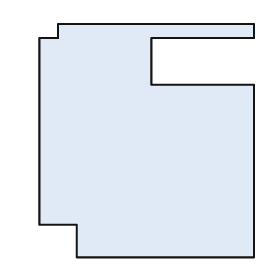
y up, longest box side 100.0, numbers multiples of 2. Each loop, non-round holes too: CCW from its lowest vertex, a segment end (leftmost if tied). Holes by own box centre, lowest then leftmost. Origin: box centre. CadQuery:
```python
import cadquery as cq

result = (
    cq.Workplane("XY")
    .moveTo(-30.0, -50.0)
    .lineTo(46.0, -50.0)
    .lineTo(46.0, 24.0)
    .lineTo(2.0, 24.0)
    .lineTo(2.0, 44.0)
    .lineTo(46.0, 44.0)
    .lineTo(46.0, 50.0)
    .lineTo(-38.0, 50.0)
    .lineTo(-38.0, 44.0)
    .lineTo(-46.0, 44.0)
    .lineTo(-46.0, -36.0)
    .lineTo(-30.0, -36.0)
    .close()
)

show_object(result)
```